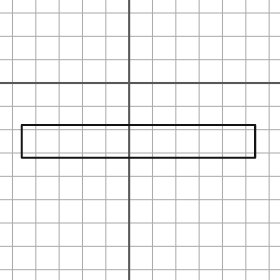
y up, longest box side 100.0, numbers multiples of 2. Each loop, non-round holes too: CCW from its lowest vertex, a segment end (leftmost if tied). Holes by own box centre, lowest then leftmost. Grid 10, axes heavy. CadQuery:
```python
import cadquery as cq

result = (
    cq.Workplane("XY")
    .moveTo(-46.0, -32.0)
    .lineTo(54.0, -32.0)
    .lineTo(54.0, -18.0)
    .lineTo(-46.0, -18.0)
    .close()
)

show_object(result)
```